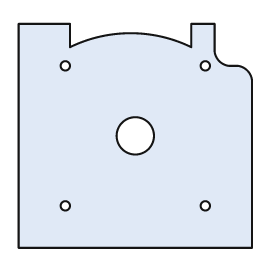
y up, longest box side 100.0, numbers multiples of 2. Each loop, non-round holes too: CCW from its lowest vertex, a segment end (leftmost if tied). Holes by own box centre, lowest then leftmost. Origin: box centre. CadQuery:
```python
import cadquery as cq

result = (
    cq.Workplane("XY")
    .moveTo(-50.0, -48.0)
    .lineTo(50.0, -48.0)
    .lineTo(50.0, 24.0)
    .threePointArc((48.0, 28.0), (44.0, 30.0))
    .lineTo(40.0, 30.0)
    .threePointArc((36.0, 32.0), (34.0, 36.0))
    .lineTo(34.0, 48.0)
    .lineTo(24.0, 48.0)
    .lineTo(24.0, 38.0)
    .threePointArc((-2.0, 44.0), (-28.0, 38.0))
    .lineTo(-28.0, 48.0)
    .lineTo(-50.0, 48.0)
    .close()
    .moveTo(-30.0, -30.0)
    .circle(2.0)
    .moveTo(30.0, -30.0)
    .circle(2.0)
    .moveTo(0.0, 0.0)
    .circle(8.0)
    .moveTo(-30.0, 30.0)
    .circle(2.0)
    .moveTo(30.0, 30.0)
    .circle(2.0)
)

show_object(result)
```